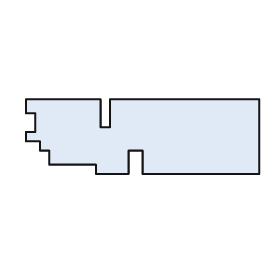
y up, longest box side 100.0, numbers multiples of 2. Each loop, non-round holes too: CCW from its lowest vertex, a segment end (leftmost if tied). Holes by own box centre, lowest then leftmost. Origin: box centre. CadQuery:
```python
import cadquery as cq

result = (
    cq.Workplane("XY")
    .moveTo(-20.0, -16.0)
    .lineTo(-6.0, -16.0)
    .lineTo(-6.0, -6.0)
    .lineTo(0.0, -6.0)
    .lineTo(0.0, -16.0)
    .lineTo(50.0, -16.0)
    .lineTo(50.0, 16.0)
    .lineTo(-14.0, 16.0)
    .lineTo(-14.0, 4.0)
    .lineTo(-18.0, 4.0)
    .lineTo(-18.0, 16.0)
    .lineTo(-50.0, 16.0)
    .lineTo(-50.0, 10.0)
    .lineTo(-46.0, 10.0)
    .lineTo(-46.0, 2.0)
    .lineTo(-50.0, 2.0)
    .lineTo(-50.0, -2.0)
    .lineTo(-44.0, -2.0)
    .lineTo(-44.0, -6.0)
    .lineTo(-40.0, -6.0)
    .lineTo(-40.0, -12.0)
    .lineTo(-20.0, -12.0)
    .close()
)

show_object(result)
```